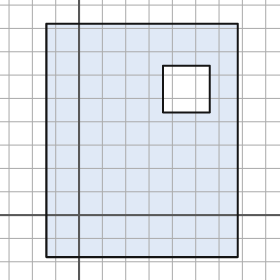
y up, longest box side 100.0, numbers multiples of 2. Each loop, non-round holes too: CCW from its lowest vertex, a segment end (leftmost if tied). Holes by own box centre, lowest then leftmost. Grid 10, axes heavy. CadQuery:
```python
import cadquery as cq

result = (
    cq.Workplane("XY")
    .moveTo(-14.0, -18.0)
    .lineTo(68.0, -18.0)
    .lineTo(68.0, 82.0)
    .lineTo(-14.0, 82.0)
    .close()
    .moveTo(36.0, 44.0)
    .lineTo(56.0, 44.0)
    .lineTo(56.0, 64.0)
    .lineTo(36.0, 64.0)
    .close()
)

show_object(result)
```